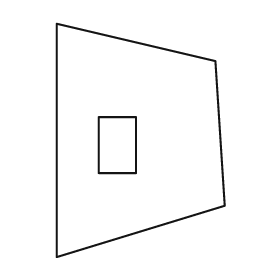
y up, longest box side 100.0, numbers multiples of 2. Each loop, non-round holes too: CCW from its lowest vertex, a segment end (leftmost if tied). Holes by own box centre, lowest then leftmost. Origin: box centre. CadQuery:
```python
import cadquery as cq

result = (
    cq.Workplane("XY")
    .moveTo(-36.0, -50.0)
    .lineTo(36.0, -28.0)
    .lineTo(32.0, 34.0)
    .lineTo(-36.0, 50.0)
    .close()
    .moveTo(-18.0, -14.0)
    .lineTo(-2.0, -14.0)
    .lineTo(-2.0, 10.0)
    .lineTo(-18.0, 10.0)
    .close()
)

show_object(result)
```